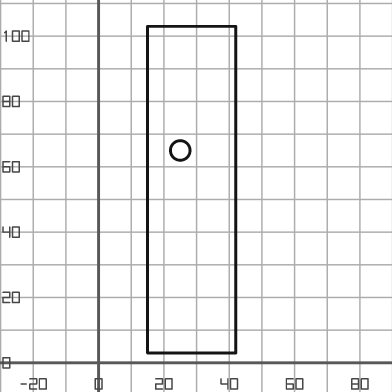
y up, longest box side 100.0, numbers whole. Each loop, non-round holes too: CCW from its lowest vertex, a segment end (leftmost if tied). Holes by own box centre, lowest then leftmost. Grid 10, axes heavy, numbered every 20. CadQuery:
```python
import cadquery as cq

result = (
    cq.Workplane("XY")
    .moveTo(15.0, 3.0)
    .lineTo(42.0, 3.0)
    .lineTo(42.0, 103.0)
    .lineTo(15.0, 103.0)
    .close()
    .moveTo(25.0, 65.0)
    .circle(3.0)
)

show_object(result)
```